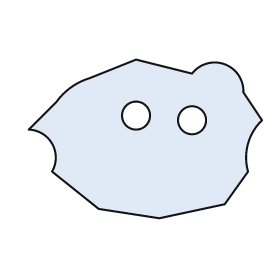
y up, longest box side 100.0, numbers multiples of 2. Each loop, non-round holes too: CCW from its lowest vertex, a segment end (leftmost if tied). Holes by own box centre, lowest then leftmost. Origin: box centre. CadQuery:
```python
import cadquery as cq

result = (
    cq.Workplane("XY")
    .moveTo(6.0, -34.0)
    .lineTo(34.0, -28.0)
    .lineTo(44.0, -14.0)
    .threePointArc((44.0, -2.0), (50.0, 8.0))
    .lineTo(42.0, 20.0)
    .threePointArc((34.0, 32.0), (20.0, 28.0))
    .lineTo(-4.0, 34.0)
    .lineTo(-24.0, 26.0)
    .threePointArc((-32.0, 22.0), (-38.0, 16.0))
    .lineTo(-50.0, 4.0)
    .threePointArc((-40.0, -2.0), (-40.0, -14.0))
    .lineTo(-20.0, -30.0)
    .close()
    .moveTo(20.0, 8.0)
    .circle(6.0)
    .moveTo(-4.0, 10.0)
    .circle(6.0)
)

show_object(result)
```